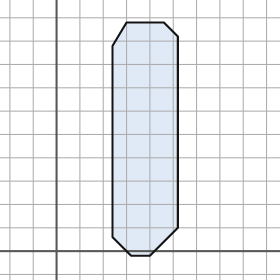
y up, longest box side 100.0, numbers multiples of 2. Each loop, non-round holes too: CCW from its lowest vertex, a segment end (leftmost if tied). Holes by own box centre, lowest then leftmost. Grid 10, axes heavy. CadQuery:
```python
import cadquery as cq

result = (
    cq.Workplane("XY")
    .moveTo(32.0, -2.0)
    .lineTo(40.0, -2.0)
    .lineTo(52.0, 10.0)
    .lineTo(52.0, 92.0)
    .lineTo(46.0, 98.0)
    .lineTo(30.0, 98.0)
    .lineTo(24.0, 88.0)
    .lineTo(24.0, 6.0)
    .close()
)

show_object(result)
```